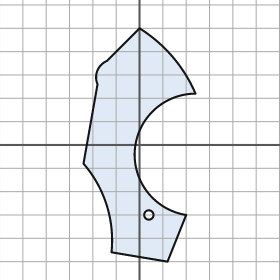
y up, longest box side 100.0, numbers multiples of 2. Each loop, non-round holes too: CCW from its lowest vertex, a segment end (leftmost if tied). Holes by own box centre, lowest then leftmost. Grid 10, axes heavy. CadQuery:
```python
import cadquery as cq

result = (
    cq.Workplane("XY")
    .moveTo(12.0, -50.0)
    .lineTo(20.0, -30.0)
    .threePointArc((-2.0, -2.0), (24.0, 22.0))
    .threePointArc((14.0, 38.0), (0.0, 50.0))
    .lineTo(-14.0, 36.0)
    .threePointArc((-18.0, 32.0), (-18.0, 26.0))
    .lineTo(-24.0, -8.0)
    .threePointArc((-14.0, -26.0), (-12.0, -46.0))
    .close()
    .moveTo(4.0, -30.0)
    .circle(2.0)
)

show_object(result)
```